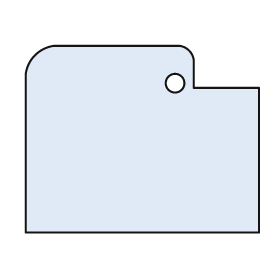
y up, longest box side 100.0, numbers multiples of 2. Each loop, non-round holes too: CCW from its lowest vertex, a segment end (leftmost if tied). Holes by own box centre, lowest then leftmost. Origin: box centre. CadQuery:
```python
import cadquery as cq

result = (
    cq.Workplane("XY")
    .moveTo(-50.0, -40.0)
    .lineTo(50.0, -40.0)
    .lineTo(50.0, 22.0)
    .lineTo(22.0, 22.0)
    .lineTo(22.0, 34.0)
    .threePointArc((20.0, 38.0), (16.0, 40.0))
    .lineTo(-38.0, 40.0)
    .threePointArc((-46.0, 36.0), (-50.0, 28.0))
    .close()
    .moveTo(14.0, 24.0)
    .circle(4.0)
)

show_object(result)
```